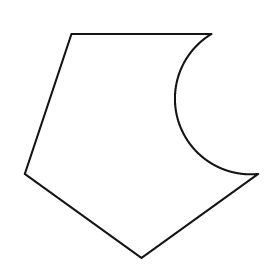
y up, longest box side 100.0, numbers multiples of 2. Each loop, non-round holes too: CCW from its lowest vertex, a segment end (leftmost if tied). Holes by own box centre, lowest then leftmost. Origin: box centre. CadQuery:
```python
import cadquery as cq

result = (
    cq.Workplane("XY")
    .moveTo(0.0, -48.0)
    .lineTo(50.0, -12.0)
    .threePointArc((16.0, 10.0), (30.0, 48.0))
    .lineTo(-30.0, 48.0)
    .lineTo(-50.0, -12.0)
    .close()
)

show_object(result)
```